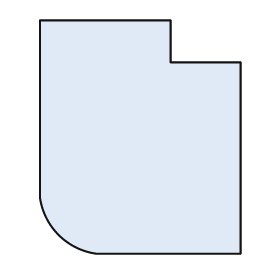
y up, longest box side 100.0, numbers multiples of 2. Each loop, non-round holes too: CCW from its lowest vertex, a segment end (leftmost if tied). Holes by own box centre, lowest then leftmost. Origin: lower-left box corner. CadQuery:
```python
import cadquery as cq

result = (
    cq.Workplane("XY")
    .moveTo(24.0, 0.0)
    .lineTo(86.0, 0.0)
    .lineTo(86.0, 82.0)
    .lineTo(56.0, 82.0)
    .lineTo(56.0, 100.0)
    .lineTo(0.0, 100.0)
    .lineTo(0.0, 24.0)
    .threePointArc((8.0, 8.0), (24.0, 0.0))
    .close()
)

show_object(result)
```